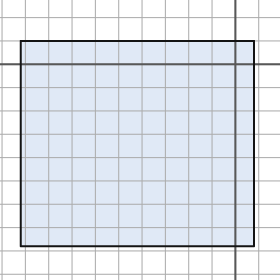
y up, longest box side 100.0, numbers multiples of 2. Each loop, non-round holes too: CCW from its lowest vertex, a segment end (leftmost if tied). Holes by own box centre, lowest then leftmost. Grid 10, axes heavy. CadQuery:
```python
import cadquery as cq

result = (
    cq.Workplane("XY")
    .moveTo(-92.0, -78.0)
    .lineTo(8.0, -78.0)
    .lineTo(8.0, 10.0)
    .lineTo(-92.0, 10.0)
    .close()
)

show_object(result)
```